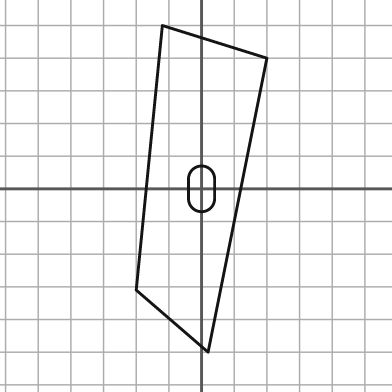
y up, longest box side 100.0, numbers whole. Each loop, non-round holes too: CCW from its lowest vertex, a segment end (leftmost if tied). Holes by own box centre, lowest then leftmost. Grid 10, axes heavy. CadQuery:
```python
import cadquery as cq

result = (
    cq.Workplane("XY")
    .moveTo(2.0, -50.0)
    .lineTo(20.0, 40.0)
    .lineTo(-12.0, 50.0)
    .lineTo(-20.0, -31.0)
    .close()
    .moveTo(-4.0, -3.0)
    .threePointArc((0.0, -7.0), (4.0, -3.0))
    .lineTo(4.0, 3.0)
    .threePointArc((0.0, 7.0), (-4.0, 3.0))
    .close()
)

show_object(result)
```